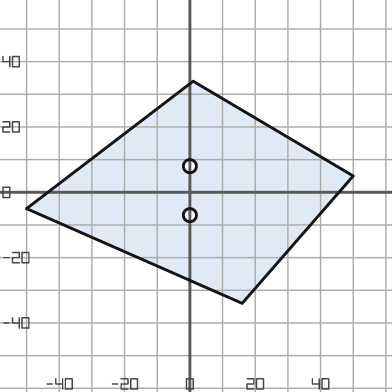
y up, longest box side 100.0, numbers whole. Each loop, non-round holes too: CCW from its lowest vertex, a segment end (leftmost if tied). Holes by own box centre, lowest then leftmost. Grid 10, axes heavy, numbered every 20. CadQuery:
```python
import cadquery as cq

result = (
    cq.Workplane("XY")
    .moveTo(16.0, -34.0)
    .lineTo(50.0, 5.0)
    .lineTo(1.0, 34.0)
    .lineTo(-50.0, -5.0)
    .close()
    .moveTo(0.0, -7.0)
    .circle(2.0)
    .moveTo(0.0, 8.0)
    .circle(2.0)
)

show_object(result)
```